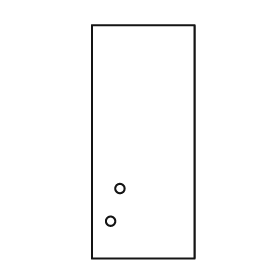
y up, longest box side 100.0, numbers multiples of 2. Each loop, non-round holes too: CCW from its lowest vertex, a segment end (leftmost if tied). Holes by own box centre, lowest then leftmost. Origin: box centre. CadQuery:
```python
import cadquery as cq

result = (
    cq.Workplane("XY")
    .moveTo(-22.0, -50.0)
    .lineTo(22.0, -50.0)
    .lineTo(22.0, 50.0)
    .lineTo(-22.0, 50.0)
    .close()
    .moveTo(-14.0, -34.0)
    .circle(2.0)
    .moveTo(-10.0, -20.0)
    .circle(2.0)
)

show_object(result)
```